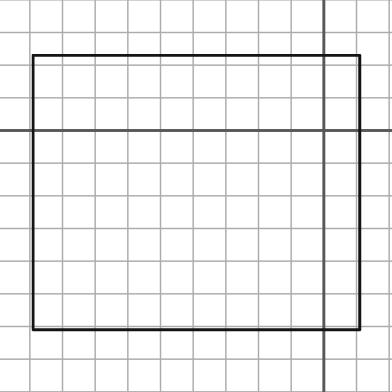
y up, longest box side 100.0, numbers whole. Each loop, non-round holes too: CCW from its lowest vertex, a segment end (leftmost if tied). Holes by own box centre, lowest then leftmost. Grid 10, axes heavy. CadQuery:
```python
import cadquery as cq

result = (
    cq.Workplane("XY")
    .moveTo(-89.0, -61.0)
    .lineTo(11.0, -61.0)
    .lineTo(11.0, 23.0)
    .lineTo(-89.0, 23.0)
    .close()
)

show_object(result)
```